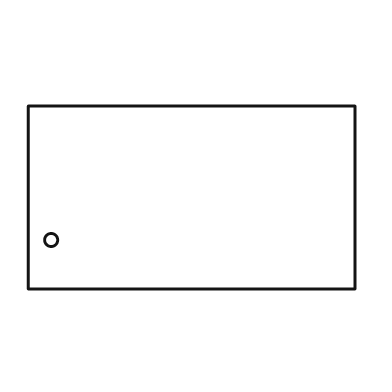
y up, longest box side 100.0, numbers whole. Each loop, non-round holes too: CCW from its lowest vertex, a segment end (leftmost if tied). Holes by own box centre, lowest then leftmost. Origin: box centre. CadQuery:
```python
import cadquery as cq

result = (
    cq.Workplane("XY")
    .moveTo(-50.0, -28.0)
    .lineTo(50.0, -28.0)
    .lineTo(50.0, 28.0)
    .lineTo(-50.0, 28.0)
    .close()
    .moveTo(-43.0, -13.0)
    .circle(2.0)
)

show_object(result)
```